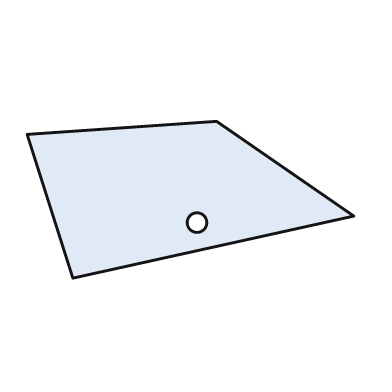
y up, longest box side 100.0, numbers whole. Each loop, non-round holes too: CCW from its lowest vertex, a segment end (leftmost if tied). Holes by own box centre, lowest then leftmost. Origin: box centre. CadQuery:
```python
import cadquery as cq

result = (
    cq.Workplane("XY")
    .moveTo(-36.0, -24.0)
    .lineTo(50.0, -5.0)
    .lineTo(8.0, 24.0)
    .lineTo(-50.0, 20.0)
    .close()
    .moveTo(2.0, -7.0)
    .circle(3.0)
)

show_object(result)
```